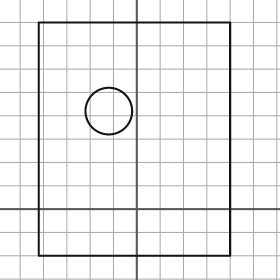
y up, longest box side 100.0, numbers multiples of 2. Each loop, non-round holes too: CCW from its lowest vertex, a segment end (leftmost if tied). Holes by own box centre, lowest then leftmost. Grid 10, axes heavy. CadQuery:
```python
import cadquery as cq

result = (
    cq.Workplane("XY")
    .moveTo(-42.0, -20.0)
    .lineTo(40.0, -20.0)
    .lineTo(40.0, 80.0)
    .lineTo(-42.0, 80.0)
    .close()
    .moveTo(-12.0, 42.0)
    .circle(10.0)
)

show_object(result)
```